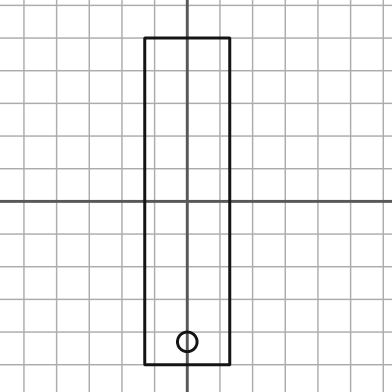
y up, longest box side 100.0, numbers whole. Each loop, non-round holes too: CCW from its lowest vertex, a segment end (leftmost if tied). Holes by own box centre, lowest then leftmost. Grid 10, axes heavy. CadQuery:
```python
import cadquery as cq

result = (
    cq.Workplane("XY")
    .moveTo(-13.0, -50.0)
    .lineTo(13.0, -50.0)
    .lineTo(13.0, 50.0)
    .lineTo(-13.0, 50.0)
    .close()
    .moveTo(0.0, -43.0)
    .circle(3.0)
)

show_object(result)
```